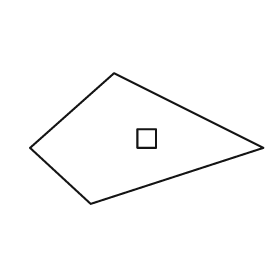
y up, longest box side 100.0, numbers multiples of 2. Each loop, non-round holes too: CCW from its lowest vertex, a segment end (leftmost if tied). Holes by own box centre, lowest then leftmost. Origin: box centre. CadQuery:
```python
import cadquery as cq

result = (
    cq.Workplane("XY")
    .moveTo(-24.0, -28.0)
    .lineTo(50.0, -4.0)
    .lineTo(-14.0, 28.0)
    .lineTo(-50.0, -4.0)
    .close()
    .moveTo(-4.0, -4.0)
    .lineTo(4.0, -4.0)
    .lineTo(4.0, 4.0)
    .lineTo(-4.0, 4.0)
    .close()
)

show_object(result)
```